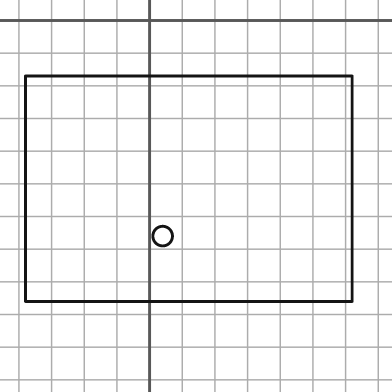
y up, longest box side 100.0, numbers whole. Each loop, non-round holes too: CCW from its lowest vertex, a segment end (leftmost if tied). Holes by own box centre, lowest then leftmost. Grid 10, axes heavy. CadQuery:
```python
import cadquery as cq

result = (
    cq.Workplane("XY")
    .moveTo(-38.0, -86.0)
    .lineTo(62.0, -86.0)
    .lineTo(62.0, -17.0)
    .lineTo(-38.0, -17.0)
    .close()
    .moveTo(4.0, -66.0)
    .circle(3.0)
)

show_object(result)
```